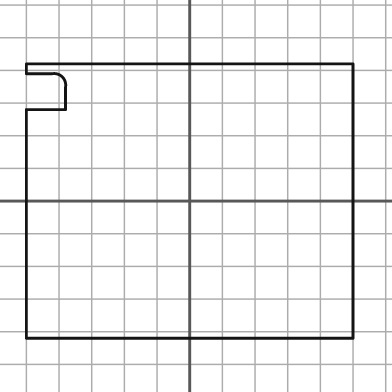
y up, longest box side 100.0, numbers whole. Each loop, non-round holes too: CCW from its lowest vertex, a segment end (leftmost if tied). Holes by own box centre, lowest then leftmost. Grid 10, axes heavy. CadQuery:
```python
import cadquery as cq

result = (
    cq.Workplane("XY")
    .moveTo(-50.0, -42.0)
    .lineTo(50.0, -42.0)
    .lineTo(50.0, 42.0)
    .lineTo(-50.0, 42.0)
    .lineTo(-50.0, 39.0)
    .lineTo(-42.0, 39.0)
    .threePointArc((-39.0, 38.0), (-38.0, 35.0))
    .lineTo(-38.0, 28.0)
    .lineTo(-50.0, 28.0)
    .close()
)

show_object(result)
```